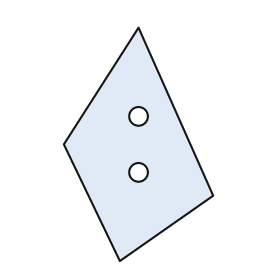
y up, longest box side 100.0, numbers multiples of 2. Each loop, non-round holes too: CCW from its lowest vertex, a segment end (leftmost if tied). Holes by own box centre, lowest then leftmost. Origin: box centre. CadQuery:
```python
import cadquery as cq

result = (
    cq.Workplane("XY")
    .moveTo(-8.0, -50.0)
    .lineTo(32.0, -22.0)
    .lineTo(0.0, 50.0)
    .lineTo(-32.0, 0.0)
    .close()
    .moveTo(0.0, -12.0)
    .circle(4.0)
    .moveTo(0.0, 12.0)
    .circle(4.0)
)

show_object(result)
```